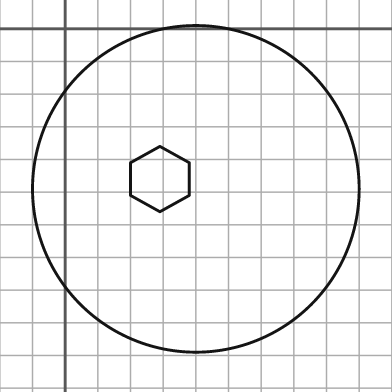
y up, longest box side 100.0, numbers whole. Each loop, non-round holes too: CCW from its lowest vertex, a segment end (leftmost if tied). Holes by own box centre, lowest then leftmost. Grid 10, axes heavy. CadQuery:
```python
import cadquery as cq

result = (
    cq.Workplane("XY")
    .moveTo(40.0, -49.0)
    .circle(50.0)
    .moveTo(29.0, -56.0)
    .lineTo(38.0, -51.0)
    .lineTo(38.0, -41.0)
    .lineTo(29.0, -36.0)
    .lineTo(20.0, -41.0)
    .lineTo(20.0, -51.0)
    .close()
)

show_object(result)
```